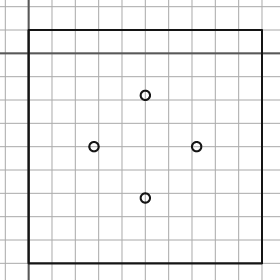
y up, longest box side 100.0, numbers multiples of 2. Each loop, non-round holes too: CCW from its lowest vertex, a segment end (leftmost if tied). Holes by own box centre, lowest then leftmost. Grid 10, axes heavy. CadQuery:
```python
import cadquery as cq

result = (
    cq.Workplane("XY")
    .moveTo(0.0, -90.0)
    .lineTo(100.0, -90.0)
    .lineTo(100.0, 10.0)
    .lineTo(0.0, 10.0)
    .close()
    .moveTo(50.0, -62.0)
    .circle(2.0)
    .moveTo(28.0, -40.0)
    .circle(2.0)
    .moveTo(72.0, -40.0)
    .circle(2.0)
    .moveTo(50.0, -18.0)
    .circle(2.0)
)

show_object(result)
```